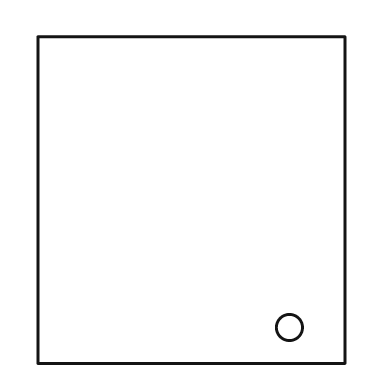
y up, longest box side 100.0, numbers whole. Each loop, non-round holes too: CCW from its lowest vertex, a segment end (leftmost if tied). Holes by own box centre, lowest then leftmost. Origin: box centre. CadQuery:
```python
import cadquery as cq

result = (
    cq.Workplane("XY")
    .moveTo(-47.0, -50.0)
    .lineTo(47.0, -50.0)
    .lineTo(47.0, 50.0)
    .lineTo(-47.0, 50.0)
    .close()
    .moveTo(30.0, -39.0)
    .circle(4.0)
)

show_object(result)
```